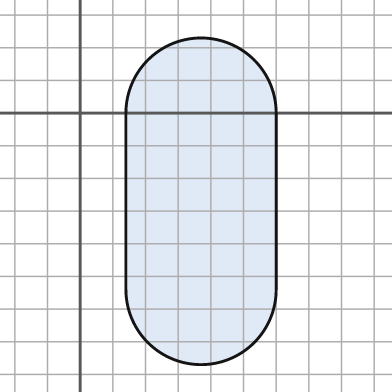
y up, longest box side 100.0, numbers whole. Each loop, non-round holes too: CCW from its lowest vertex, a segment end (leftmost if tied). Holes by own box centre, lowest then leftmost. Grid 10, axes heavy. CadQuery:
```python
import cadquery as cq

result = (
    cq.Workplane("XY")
    .moveTo(14.0, -54.0)
    .threePointArc((37.0, -77.0), (60.0, -54.0))
    .lineTo(60.0, 0.0)
    .threePointArc((37.0, 23.0), (14.0, 0.0))
    .close()
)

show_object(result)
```